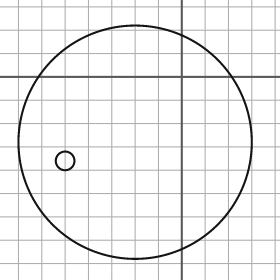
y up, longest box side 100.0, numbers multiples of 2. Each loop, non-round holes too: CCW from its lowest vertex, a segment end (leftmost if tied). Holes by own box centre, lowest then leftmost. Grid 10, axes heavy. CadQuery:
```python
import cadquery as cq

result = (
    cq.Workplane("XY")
    .moveTo(-20.0, -28.0)
    .circle(50.0)
    .moveTo(-50.0, -36.0)
    .circle(4.0)
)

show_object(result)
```